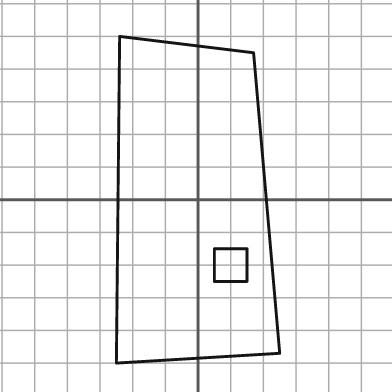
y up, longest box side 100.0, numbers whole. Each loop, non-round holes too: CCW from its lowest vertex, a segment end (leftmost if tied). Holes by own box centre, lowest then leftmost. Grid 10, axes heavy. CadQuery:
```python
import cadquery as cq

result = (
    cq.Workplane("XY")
    .moveTo(-25.0, -50.0)
    .lineTo(25.0, -47.0)
    .lineTo(17.0, 45.0)
    .lineTo(-24.0, 50.0)
    .close()
    .moveTo(5.0, -25.0)
    .lineTo(15.0, -25.0)
    .lineTo(15.0, -15.0)
    .lineTo(5.0, -15.0)
    .close()
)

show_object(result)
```